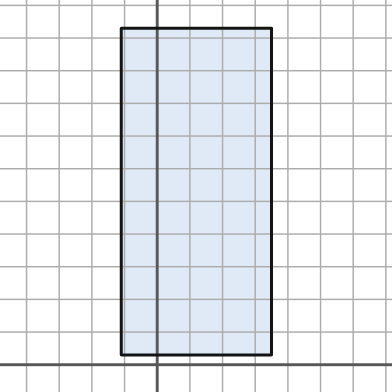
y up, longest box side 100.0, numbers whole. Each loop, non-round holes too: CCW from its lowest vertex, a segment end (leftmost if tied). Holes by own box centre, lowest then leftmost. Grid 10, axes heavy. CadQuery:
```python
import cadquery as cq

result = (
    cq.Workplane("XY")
    .moveTo(-11.0, 3.0)
    .lineTo(35.0, 3.0)
    .lineTo(35.0, 103.0)
    .lineTo(-11.0, 103.0)
    .close()
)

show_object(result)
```